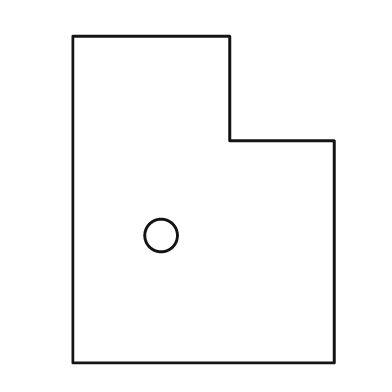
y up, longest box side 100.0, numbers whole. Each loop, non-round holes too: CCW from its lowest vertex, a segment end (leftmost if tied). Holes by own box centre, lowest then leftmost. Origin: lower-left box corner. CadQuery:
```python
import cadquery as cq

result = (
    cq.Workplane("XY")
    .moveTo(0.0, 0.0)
    .lineTo(80.0, 0.0)
    .lineTo(80.0, 68.0)
    .lineTo(48.0, 68.0)
    .lineTo(48.0, 100.0)
    .lineTo(0.0, 100.0)
    .close()
    .moveTo(27.0, 39.0)
    .circle(5.0)
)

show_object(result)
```